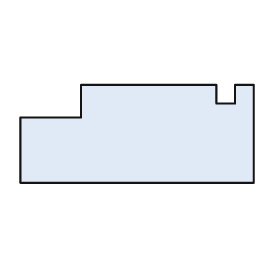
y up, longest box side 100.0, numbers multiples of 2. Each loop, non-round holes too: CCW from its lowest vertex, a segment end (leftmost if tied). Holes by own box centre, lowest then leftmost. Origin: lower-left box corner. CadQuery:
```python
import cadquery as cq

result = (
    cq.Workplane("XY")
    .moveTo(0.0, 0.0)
    .lineTo(100.0, 0.0)
    .lineTo(100.0, 42.0)
    .lineTo(92.0, 42.0)
    .lineTo(92.0, 34.0)
    .lineTo(84.0, 34.0)
    .lineTo(84.0, 42.0)
    .lineTo(26.0, 42.0)
    .lineTo(26.0, 28.0)
    .lineTo(0.0, 28.0)
    .close()
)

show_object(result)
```